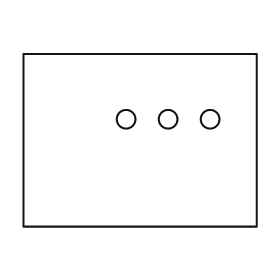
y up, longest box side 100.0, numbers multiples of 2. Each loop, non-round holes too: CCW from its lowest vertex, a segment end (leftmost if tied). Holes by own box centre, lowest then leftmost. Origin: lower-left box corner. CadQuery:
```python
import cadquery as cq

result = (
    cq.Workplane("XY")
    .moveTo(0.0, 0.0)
    .lineTo(100.0, 0.0)
    .lineTo(100.0, 74.0)
    .lineTo(0.0, 74.0)
    .close()
    .moveTo(44.0, 46.0)
    .circle(4.0)
    .moveTo(62.0, 46.0)
    .circle(4.0)
    .moveTo(80.0, 46.0)
    .circle(4.0)
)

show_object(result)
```